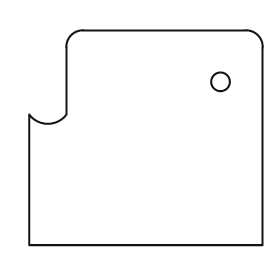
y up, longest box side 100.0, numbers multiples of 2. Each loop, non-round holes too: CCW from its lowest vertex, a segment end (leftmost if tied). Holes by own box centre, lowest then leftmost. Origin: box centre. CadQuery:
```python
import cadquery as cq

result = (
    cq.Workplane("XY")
    .moveTo(-50.0, -46.0)
    .lineTo(50.0, -46.0)
    .lineTo(50.0, 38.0)
    .threePointArc((48.0, 44.0), (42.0, 46.0))
    .lineTo(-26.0, 46.0)
    .threePointArc((-32.0, 44.0), (-34.0, 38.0))
    .lineTo(-34.0, 10.0)
    .threePointArc((-42.0, 6.0), (-50.0, 10.0))
    .close()
    .moveTo(32.0, 24.0)
    .circle(4.0)
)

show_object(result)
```